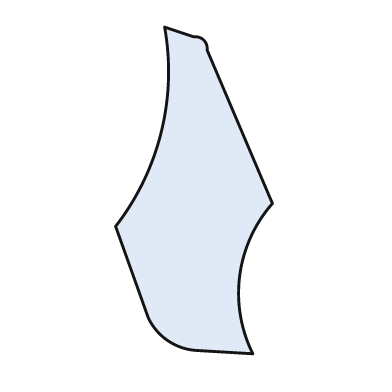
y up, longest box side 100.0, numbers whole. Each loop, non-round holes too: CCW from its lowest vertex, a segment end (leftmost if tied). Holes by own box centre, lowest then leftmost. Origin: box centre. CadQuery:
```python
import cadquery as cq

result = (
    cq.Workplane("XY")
    .moveTo(18.0, -50.0)
    .threePointArc((14.0, -26.0), (24.0, -4.0))
    .lineTo(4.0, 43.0)
    .threePointArc((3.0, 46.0), (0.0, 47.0))
    .lineTo(-9.0, 50.0)
    .threePointArc((-10.0, 18.0), (-24.0, -11.0))
    .lineTo(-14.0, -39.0)
    .threePointArc((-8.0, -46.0), (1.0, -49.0))
    .close()
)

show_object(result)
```